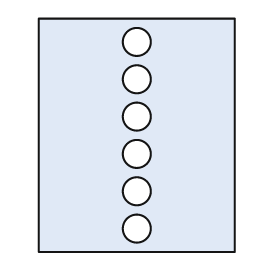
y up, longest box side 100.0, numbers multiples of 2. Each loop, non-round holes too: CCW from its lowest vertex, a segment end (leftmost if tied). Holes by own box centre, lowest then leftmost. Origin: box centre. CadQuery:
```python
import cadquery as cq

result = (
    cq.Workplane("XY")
    .moveTo(-42.0, -50.0)
    .lineTo(42.0, -50.0)
    .lineTo(42.0, 50.0)
    .lineTo(-42.0, 50.0)
    .close()
    .moveTo(0.0, -40.0)
    .circle(6.0)
    .moveTo(0.0, -24.0)
    .circle(6.0)
    .moveTo(0.0, -8.0)
    .circle(6.0)
    .moveTo(0.0, 8.0)
    .circle(6.0)
    .moveTo(0.0, 24.0)
    .circle(6.0)
    .moveTo(0.0, 40.0)
    .circle(6.0)
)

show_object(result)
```